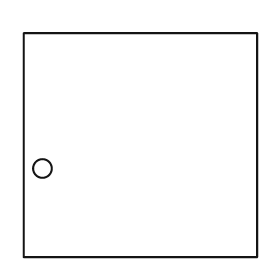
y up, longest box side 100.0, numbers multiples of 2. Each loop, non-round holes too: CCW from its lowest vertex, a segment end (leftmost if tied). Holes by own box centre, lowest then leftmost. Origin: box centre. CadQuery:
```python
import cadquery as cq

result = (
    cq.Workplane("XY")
    .moveTo(-50.0, -48.0)
    .lineTo(50.0, -48.0)
    .lineTo(50.0, 48.0)
    .lineTo(-50.0, 48.0)
    .close()
    .moveTo(-42.0, -10.0)
    .circle(4.0)
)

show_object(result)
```